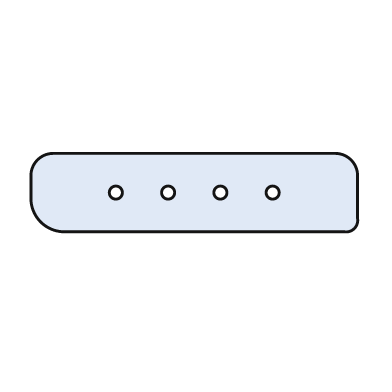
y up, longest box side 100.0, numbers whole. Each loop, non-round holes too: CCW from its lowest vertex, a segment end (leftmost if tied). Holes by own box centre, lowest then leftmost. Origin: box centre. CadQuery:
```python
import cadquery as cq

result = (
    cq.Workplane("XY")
    .moveTo(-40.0, -12.0)
    .lineTo(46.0, -12.0)
    .threePointArc((49.0, -11.0), (50.0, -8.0))
    .lineTo(50.0, 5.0)
    .threePointArc((48.0, 10.0), (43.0, 12.0))
    .lineTo(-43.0, 12.0)
    .threePointArc((-48.0, 10.0), (-50.0, 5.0))
    .lineTo(-50.0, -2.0)
    .threePointArc((-47.0, -9.0), (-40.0, -12.0))
    .close()
    .moveTo(-24.0, 0.0)
    .circle(2.0)
    .moveTo(-8.0, 0.0)
    .circle(2.0)
    .moveTo(8.0, 0.0)
    .circle(2.0)
    .moveTo(24.0, 0.0)
    .circle(2.0)
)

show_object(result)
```